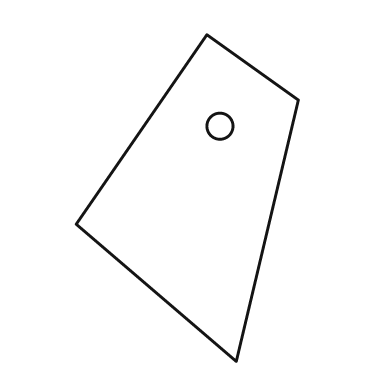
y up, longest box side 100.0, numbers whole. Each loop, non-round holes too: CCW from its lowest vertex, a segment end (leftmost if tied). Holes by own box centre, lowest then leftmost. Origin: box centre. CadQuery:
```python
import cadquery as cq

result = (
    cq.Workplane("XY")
    .moveTo(15.0, -50.0)
    .lineTo(34.0, 30.0)
    .lineTo(6.0, 50.0)
    .lineTo(-34.0, -8.0)
    .close()
    .moveTo(10.0, 22.0)
    .circle(4.0)
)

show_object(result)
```